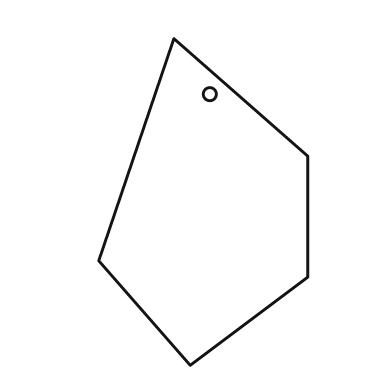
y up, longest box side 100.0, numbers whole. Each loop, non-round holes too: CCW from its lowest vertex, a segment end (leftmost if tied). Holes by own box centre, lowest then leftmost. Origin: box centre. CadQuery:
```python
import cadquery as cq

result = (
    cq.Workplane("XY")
    .moveTo(-4.0, -50.0)
    .lineTo(32.0, -23.0)
    .lineTo(32.0, 14.0)
    .lineTo(-9.0, 50.0)
    .lineTo(-32.0, -18.0)
    .close()
    .moveTo(2.0, 33.0)
    .circle(2.0)
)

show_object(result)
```